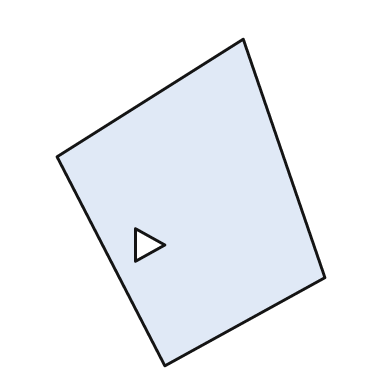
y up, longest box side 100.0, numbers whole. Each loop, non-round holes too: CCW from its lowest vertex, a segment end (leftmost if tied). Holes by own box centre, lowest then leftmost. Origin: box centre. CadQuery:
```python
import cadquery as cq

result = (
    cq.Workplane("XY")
    .moveTo(-8.0, -50.0)
    .lineTo(41.0, -23.0)
    .lineTo(16.0, 50.0)
    .lineTo(-41.0, 14.0)
    .close()
    .moveTo(-17.0, -18.0)
    .lineTo(-8.0, -13.0)
    .lineTo(-17.0, -8.0)
    .close()
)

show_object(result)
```